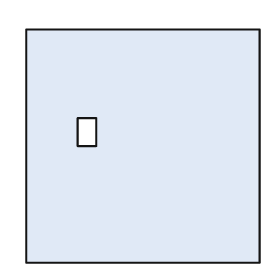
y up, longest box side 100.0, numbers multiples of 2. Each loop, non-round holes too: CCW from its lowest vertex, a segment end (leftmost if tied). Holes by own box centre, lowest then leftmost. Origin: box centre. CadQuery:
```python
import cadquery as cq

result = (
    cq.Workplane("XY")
    .moveTo(-50.0, -50.0)
    .lineTo(50.0, -50.0)
    .lineTo(50.0, 50.0)
    .lineTo(-50.0, 50.0)
    .close()
    .moveTo(-28.0, 0.0)
    .lineTo(-20.0, 0.0)
    .lineTo(-20.0, 12.0)
    .lineTo(-28.0, 12.0)
    .close()
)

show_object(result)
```